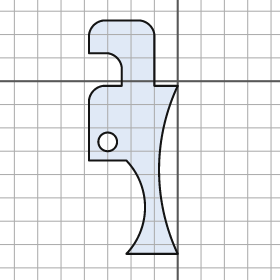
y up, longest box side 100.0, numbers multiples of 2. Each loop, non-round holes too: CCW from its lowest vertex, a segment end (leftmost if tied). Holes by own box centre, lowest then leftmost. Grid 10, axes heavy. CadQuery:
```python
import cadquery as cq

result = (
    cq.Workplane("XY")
    .moveTo(-22.0, -74.0)
    .lineTo(0.0, -74.0)
    .threePointArc((-8.0, -38.0), (0.0, -2.0))
    .lineTo(-10.0, -2.0)
    .lineTo(-10.0, 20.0)
    .threePointArc((-12.0, 24.0), (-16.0, 26.0))
    .lineTo(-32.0, 26.0)
    .threePointArc((-36.0, 24.0), (-38.0, 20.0))
    .lineTo(-38.0, 12.0)
    .lineTo(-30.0, 12.0)
    .threePointArc((-26.0, 10.0), (-24.0, 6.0))
    .lineTo(-24.0, -2.0)
    .lineTo(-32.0, -2.0)
    .threePointArc((-36.0, -4.0), (-38.0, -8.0))
    .lineTo(-38.0, -34.0)
    .lineTo(-22.0, -34.0)
    .threePointArc((-14.0, -54.0), (-22.0, -74.0))
    .close()
    .moveTo(-30.0, -26.0)
    .circle(4.0)
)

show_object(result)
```